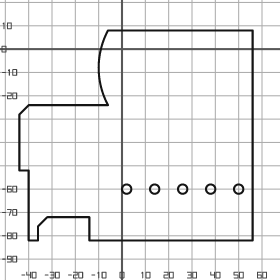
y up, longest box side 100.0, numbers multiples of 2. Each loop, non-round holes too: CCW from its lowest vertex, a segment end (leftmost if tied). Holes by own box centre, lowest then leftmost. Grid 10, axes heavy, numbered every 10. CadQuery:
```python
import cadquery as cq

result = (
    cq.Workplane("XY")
    .moveTo(-40.0, -82.0)
    .lineTo(-36.0, -82.0)
    .lineTo(-36.0, -76.0)
    .lineTo(-32.0, -72.0)
    .lineTo(-14.0, -72.0)
    .lineTo(-14.0, -82.0)
    .lineTo(56.0, -82.0)
    .lineTo(56.0, 8.0)
    .lineTo(-6.0, 8.0)
    .threePointArc((-10.0, -8.0), (-6.0, -24.0))
    .lineTo(-40.0, -24.0)
    .lineTo(-44.0, -28.0)
    .lineTo(-44.0, -52.0)
    .lineTo(-40.0, -52.0)
    .close()
    .moveTo(2.0, -60.0)
    .circle(2.0)
    .moveTo(14.0, -60.0)
    .circle(2.0)
    .moveTo(26.0, -60.0)
    .circle(2.0)
    .moveTo(38.0, -60.0)
    .circle(2.0)
    .moveTo(50.0, -60.0)
    .circle(2.0)
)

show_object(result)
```